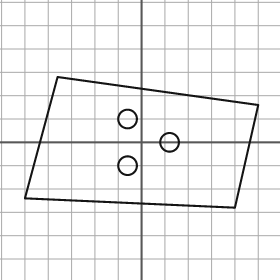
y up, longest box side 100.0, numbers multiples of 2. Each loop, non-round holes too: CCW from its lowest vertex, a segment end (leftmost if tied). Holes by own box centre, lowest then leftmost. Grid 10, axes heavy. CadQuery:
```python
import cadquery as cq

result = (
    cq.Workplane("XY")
    .moveTo(40.0, -28.0)
    .lineTo(50.0, 16.0)
    .lineTo(-36.0, 28.0)
    .lineTo(-50.0, -24.0)
    .close()
    .moveTo(-6.0, -10.0)
    .circle(4.0)
    .moveTo(12.0, 0.0)
    .circle(4.0)
    .moveTo(-6.0, 10.0)
    .circle(4.0)
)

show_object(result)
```